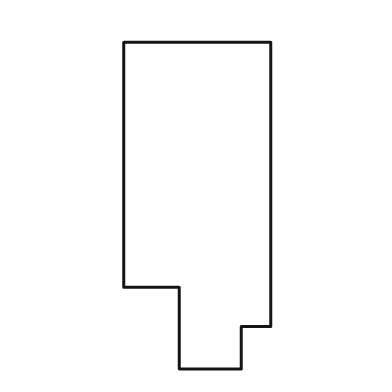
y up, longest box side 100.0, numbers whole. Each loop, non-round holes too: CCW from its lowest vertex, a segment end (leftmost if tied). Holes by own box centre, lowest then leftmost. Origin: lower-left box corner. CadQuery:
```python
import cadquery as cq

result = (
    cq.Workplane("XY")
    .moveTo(17.0, 0.0)
    .lineTo(36.0, 0.0)
    .lineTo(36.0, 13.0)
    .lineTo(45.0, 13.0)
    .lineTo(45.0, 100.0)
    .lineTo(0.0, 100.0)
    .lineTo(0.0, 25.0)
    .lineTo(17.0, 25.0)
    .close()
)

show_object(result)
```